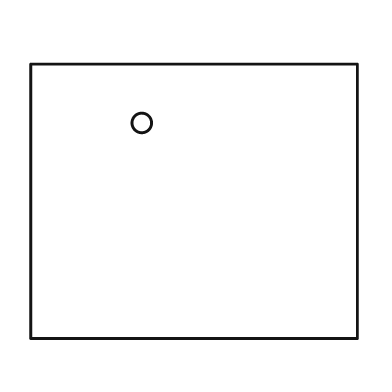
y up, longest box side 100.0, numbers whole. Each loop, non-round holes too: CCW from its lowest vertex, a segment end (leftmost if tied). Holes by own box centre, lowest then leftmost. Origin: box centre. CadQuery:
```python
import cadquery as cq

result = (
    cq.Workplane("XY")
    .moveTo(-50.0, -42.0)
    .lineTo(50.0, -42.0)
    .lineTo(50.0, 42.0)
    .lineTo(-50.0, 42.0)
    .close()
    .moveTo(-16.0, 24.0)
    .circle(3.0)
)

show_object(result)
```